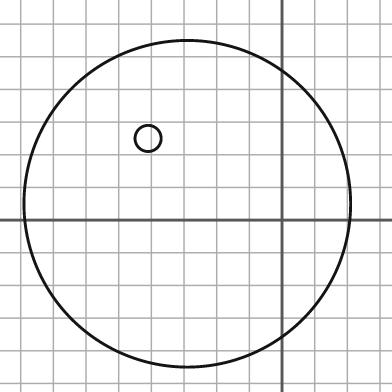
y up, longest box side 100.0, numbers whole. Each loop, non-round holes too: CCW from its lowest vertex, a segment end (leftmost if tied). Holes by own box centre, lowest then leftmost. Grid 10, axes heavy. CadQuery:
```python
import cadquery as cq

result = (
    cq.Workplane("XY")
    .moveTo(-29.0, 5.0)
    .circle(50.0)
    .moveTo(-41.0, 25.0)
    .circle(4.0)
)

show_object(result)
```